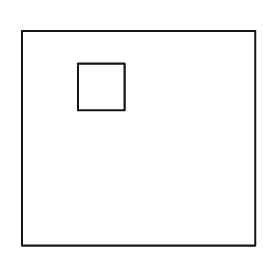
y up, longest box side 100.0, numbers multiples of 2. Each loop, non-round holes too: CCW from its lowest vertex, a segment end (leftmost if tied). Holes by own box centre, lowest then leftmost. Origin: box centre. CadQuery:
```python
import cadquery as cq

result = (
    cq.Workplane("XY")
    .moveTo(-50.0, -46.0)
    .lineTo(50.0, -46.0)
    .lineTo(50.0, 46.0)
    .lineTo(-50.0, 46.0)
    .close()
    .moveTo(-26.0, 12.0)
    .lineTo(-6.0, 12.0)
    .lineTo(-6.0, 32.0)
    .lineTo(-26.0, 32.0)
    .close()
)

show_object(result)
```